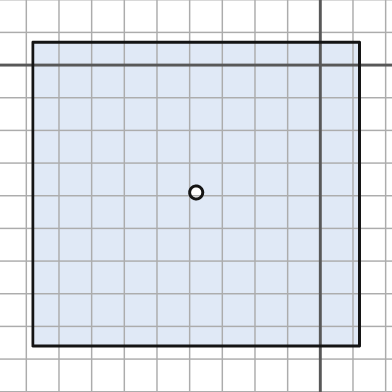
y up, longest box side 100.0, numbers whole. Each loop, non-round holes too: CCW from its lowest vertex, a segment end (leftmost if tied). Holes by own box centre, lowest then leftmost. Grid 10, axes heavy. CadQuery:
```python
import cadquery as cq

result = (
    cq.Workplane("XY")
    .moveTo(-88.0, -86.0)
    .lineTo(12.0, -86.0)
    .lineTo(12.0, 7.0)
    .lineTo(-88.0, 7.0)
    .close()
    .moveTo(-38.0, -39.0)
    .circle(2.0)
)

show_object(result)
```